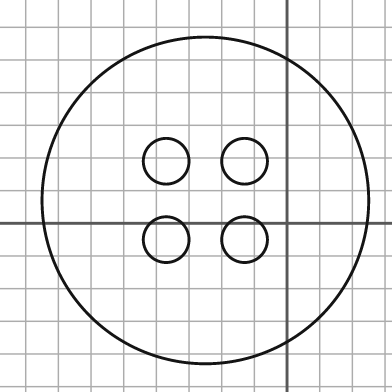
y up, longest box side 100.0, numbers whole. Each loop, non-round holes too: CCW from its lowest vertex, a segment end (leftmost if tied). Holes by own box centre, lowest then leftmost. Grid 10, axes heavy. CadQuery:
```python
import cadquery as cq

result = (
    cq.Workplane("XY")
    .moveTo(-25.0, 7.0)
    .circle(50.0)
    .moveTo(-37.0, -5.0)
    .circle(7.0)
    .moveTo(-13.0, -5.0)
    .circle(7.0)
    .moveTo(-37.0, 19.0)
    .circle(7.0)
    .moveTo(-13.0, 19.0)
    .circle(7.0)
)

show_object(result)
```